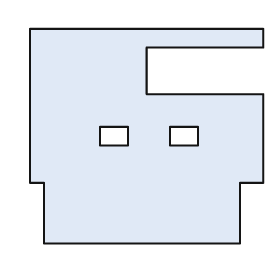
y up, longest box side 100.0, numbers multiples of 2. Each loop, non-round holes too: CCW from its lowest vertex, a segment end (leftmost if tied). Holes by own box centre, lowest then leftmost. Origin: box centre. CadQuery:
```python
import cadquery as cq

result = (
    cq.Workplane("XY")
    .moveTo(-44.0, -46.0)
    .lineTo(40.0, -46.0)
    .lineTo(40.0, -20.0)
    .lineTo(50.0, -20.0)
    .lineTo(50.0, 18.0)
    .lineTo(0.0, 18.0)
    .lineTo(0.0, 38.0)
    .lineTo(50.0, 38.0)
    .lineTo(50.0, 46.0)
    .lineTo(-50.0, 46.0)
    .lineTo(-50.0, -20.0)
    .lineTo(-44.0, -20.0)
    .close()
    .moveTo(-20.0, -4.0)
    .lineTo(-8.0, -4.0)
    .lineTo(-8.0, 4.0)
    .lineTo(-20.0, 4.0)
    .close()
    .moveTo(10.0, -4.0)
    .lineTo(22.0, -4.0)
    .lineTo(22.0, 4.0)
    .lineTo(10.0, 4.0)
    .close()
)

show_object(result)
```